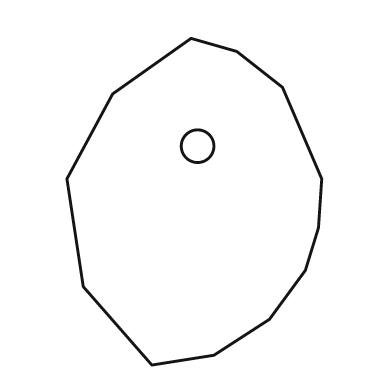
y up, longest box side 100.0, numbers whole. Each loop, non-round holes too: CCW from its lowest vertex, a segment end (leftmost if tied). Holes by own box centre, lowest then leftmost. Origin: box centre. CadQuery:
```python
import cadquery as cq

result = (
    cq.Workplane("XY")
    .moveTo(-13.0, -50.0)
    .lineTo(6.0, -47.0)
    .lineTo(23.0, -36.0)
    .lineTo(34.0, -21.0)
    .lineTo(38.0, -8.0)
    .lineTo(39.0, 7.0)
    .lineTo(27.0, 35.0)
    .lineTo(13.0, 46.0)
    .lineTo(-1.0, 50.0)
    .lineTo(-25.0, 33.0)
    .lineTo(-39.0, 7.0)
    .lineTo(-34.0, -26.0)
    .close()
    .moveTo(1.0, 17.0)
    .circle(5.0)
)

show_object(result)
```